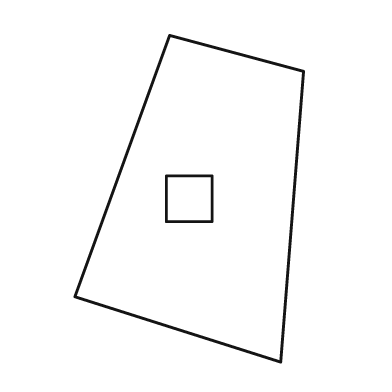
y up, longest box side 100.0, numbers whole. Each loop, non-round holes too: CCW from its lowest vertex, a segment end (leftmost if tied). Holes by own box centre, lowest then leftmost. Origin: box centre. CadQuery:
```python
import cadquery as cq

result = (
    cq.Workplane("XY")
    .moveTo(28.0, -50.0)
    .lineTo(35.0, 39.0)
    .lineTo(-6.0, 50.0)
    .lineTo(-35.0, -30.0)
    .close()
    .moveTo(-7.0, -7.0)
    .lineTo(7.0, -7.0)
    .lineTo(7.0, 7.0)
    .lineTo(-7.0, 7.0)
    .close()
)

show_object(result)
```